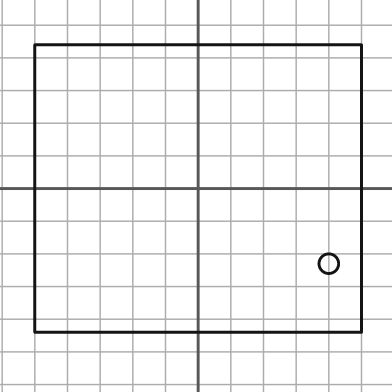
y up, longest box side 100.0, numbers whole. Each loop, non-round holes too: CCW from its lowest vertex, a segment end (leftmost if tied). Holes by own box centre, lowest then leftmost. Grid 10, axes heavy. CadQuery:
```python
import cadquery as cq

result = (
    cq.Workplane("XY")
    .moveTo(-50.0, -44.0)
    .lineTo(50.0, -44.0)
    .lineTo(50.0, 44.0)
    .lineTo(-50.0, 44.0)
    .close()
    .moveTo(40.0, -23.0)
    .circle(3.0)
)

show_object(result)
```